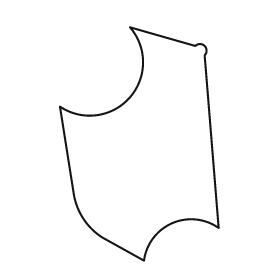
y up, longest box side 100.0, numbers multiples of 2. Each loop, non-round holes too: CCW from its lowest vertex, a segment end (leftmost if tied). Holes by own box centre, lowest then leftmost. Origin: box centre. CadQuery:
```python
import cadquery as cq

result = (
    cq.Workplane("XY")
    .moveTo(2.0, -50.0)
    .threePointArc((14.0, -34.0), (34.0, -36.0))
    .lineTo(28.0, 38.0)
    .threePointArc((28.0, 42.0), (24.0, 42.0))
    .lineTo(-4.0, 50.0)
    .threePointArc((-4.0, 20.0), (-34.0, 16.0))
    .lineTo(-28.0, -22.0)
    .threePointArc((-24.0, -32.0), (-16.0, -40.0))
    .close()
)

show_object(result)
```